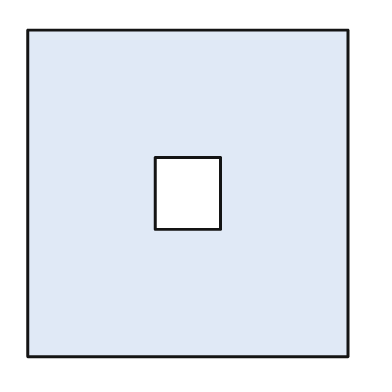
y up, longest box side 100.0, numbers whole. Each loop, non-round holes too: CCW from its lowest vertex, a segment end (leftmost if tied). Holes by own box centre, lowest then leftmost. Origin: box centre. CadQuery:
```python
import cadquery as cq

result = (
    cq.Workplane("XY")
    .moveTo(-49.0, -50.0)
    .lineTo(49.0, -50.0)
    .lineTo(49.0, 50.0)
    .lineTo(-49.0, 50.0)
    .close()
    .moveTo(-10.0, -11.0)
    .lineTo(10.0, -11.0)
    .lineTo(10.0, 11.0)
    .lineTo(-10.0, 11.0)
    .close()
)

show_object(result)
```